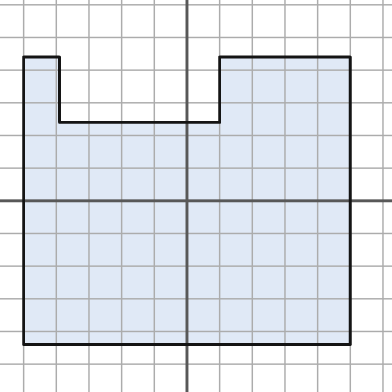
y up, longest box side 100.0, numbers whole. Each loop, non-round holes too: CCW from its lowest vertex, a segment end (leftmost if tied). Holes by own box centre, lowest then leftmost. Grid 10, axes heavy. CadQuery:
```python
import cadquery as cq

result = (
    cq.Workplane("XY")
    .moveTo(-50.0, -44.0)
    .lineTo(50.0, -44.0)
    .lineTo(50.0, 44.0)
    .lineTo(10.0, 44.0)
    .lineTo(10.0, 24.0)
    .lineTo(-39.0, 24.0)
    .lineTo(-39.0, 44.0)
    .lineTo(-50.0, 44.0)
    .close()
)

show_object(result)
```